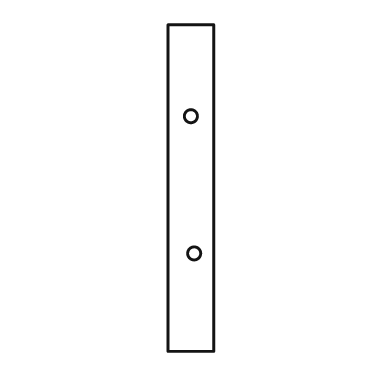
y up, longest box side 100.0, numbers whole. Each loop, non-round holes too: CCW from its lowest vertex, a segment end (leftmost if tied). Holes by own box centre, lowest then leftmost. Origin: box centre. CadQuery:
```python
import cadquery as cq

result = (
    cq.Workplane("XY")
    .moveTo(-7.0, -50.0)
    .lineTo(7.0, -50.0)
    .lineTo(7.0, 50.0)
    .lineTo(-7.0, 50.0)
    .close()
    .moveTo(1.0, -20.0)
    .circle(2.0)
    .moveTo(0.0, 22.0)
    .circle(2.0)
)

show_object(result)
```